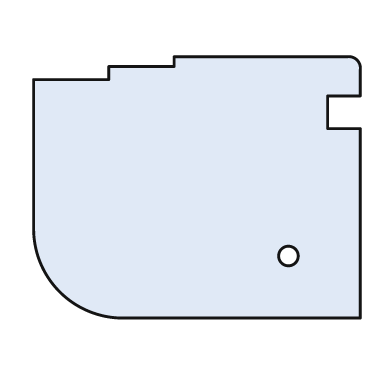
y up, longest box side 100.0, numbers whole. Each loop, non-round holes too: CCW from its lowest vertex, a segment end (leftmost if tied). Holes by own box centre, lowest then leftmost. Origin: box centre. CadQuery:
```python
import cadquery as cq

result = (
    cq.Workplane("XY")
    .moveTo(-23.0, -40.0)
    .lineTo(50.0, -40.0)
    .lineTo(50.0, 18.0)
    .lineTo(40.0, 18.0)
    .lineTo(40.0, 28.0)
    .lineTo(50.0, 28.0)
    .lineTo(50.0, 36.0)
    .threePointArc((49.0, 39.0), (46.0, 40.0))
    .lineTo(-7.0, 40.0)
    .lineTo(-7.0, 37.0)
    .lineTo(-27.0, 37.0)
    .lineTo(-27.0, 33.0)
    .lineTo(-50.0, 33.0)
    .lineTo(-50.0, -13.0)
    .threePointArc((-42.0, -32.0), (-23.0, -40.0))
    .close()
    .moveTo(28.0, -21.0)
    .circle(3.0)
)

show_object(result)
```